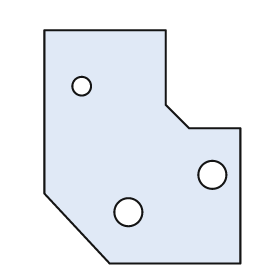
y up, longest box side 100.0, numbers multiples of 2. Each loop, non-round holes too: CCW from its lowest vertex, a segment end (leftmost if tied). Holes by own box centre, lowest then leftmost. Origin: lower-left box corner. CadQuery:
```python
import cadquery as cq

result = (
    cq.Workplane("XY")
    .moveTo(28.0, 0.0)
    .lineTo(84.0, 0.0)
    .lineTo(84.0, 58.0)
    .lineTo(62.0, 58.0)
    .lineTo(52.0, 68.0)
    .lineTo(52.0, 100.0)
    .lineTo(0.0, 100.0)
    .lineTo(0.0, 30.0)
    .close()
    .moveTo(36.0, 22.0)
    .circle(6.0)
    .moveTo(72.0, 38.0)
    .circle(6.0)
    .moveTo(16.0, 76.0)
    .circle(4.0)
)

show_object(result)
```